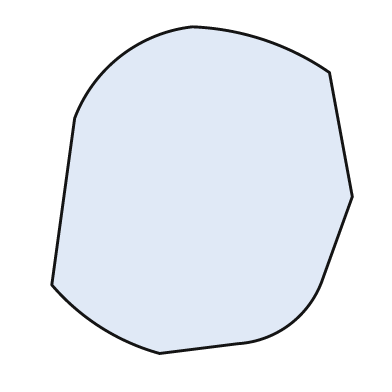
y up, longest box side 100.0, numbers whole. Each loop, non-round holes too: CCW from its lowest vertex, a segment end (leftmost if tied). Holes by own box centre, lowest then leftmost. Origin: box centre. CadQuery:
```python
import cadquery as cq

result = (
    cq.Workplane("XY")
    .moveTo(-13.0, -50.0)
    .lineTo(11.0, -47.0)
    .threePointArc((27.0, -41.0), (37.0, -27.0))
    .lineTo(46.0, -2.0)
    .lineTo(39.0, 36.0)
    .threePointArc((19.0, 46.0), (-3.0, 50.0))
    .threePointArc((-25.0, 41.0), (-39.0, 22.0))
    .lineTo(-46.0, -29.0)
    .threePointArc((-31.0, -42.0), (-13.0, -50.0))
    .close()
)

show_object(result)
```